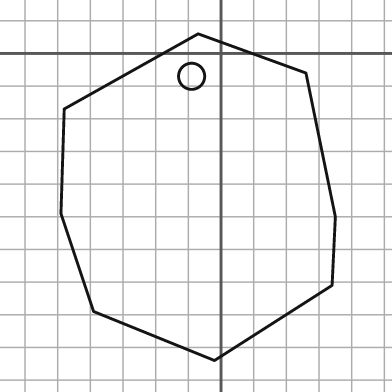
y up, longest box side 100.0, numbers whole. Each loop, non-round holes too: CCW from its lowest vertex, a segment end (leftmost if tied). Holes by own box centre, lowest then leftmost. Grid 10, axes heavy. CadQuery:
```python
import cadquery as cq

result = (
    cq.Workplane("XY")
    .moveTo(-2.0, -94.0)
    .lineTo(34.0, -71.0)
    .lineTo(35.0, -50.0)
    .lineTo(26.0, -6.0)
    .lineTo(-7.0, 6.0)
    .lineTo(-48.0, -17.0)
    .lineTo(-49.0, -49.0)
    .lineTo(-39.0, -79.0)
    .close()
    .moveTo(-9.0, -7.0)
    .circle(4.0)
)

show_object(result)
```